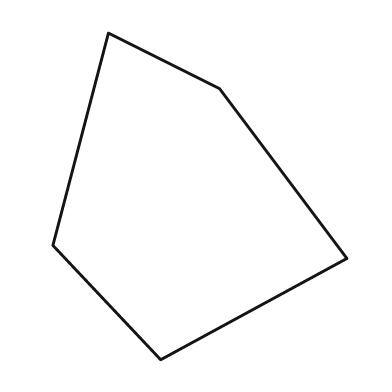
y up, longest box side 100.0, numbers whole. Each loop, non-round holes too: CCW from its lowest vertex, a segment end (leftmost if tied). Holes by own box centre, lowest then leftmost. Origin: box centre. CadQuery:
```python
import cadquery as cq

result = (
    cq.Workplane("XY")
    .moveTo(-12.0, -50.0)
    .lineTo(45.0, -19.0)
    .lineTo(6.0, 33.0)
    .lineTo(-28.0, 50.0)
    .lineTo(-45.0, -15.0)
    .close()
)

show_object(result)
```